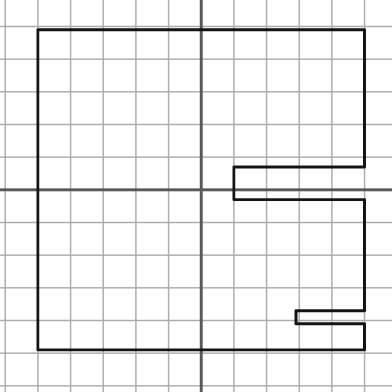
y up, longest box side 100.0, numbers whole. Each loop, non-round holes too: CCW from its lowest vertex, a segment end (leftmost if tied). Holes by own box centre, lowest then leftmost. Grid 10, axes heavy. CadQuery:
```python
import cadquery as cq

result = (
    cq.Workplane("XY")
    .moveTo(-50.0, -49.0)
    .lineTo(50.0, -49.0)
    .lineTo(50.0, -41.0)
    .lineTo(29.0, -41.0)
    .lineTo(29.0, -37.0)
    .lineTo(50.0, -37.0)
    .lineTo(50.0, -3.0)
    .lineTo(10.0, -3.0)
    .lineTo(10.0, 7.0)
    .lineTo(50.0, 7.0)
    .lineTo(50.0, 49.0)
    .lineTo(-50.0, 49.0)
    .close()
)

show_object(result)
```